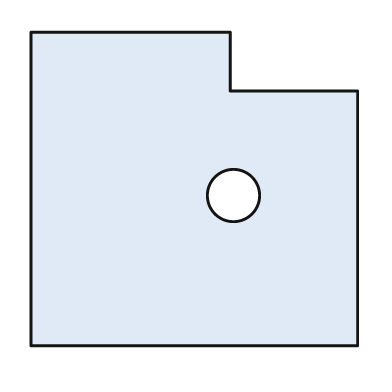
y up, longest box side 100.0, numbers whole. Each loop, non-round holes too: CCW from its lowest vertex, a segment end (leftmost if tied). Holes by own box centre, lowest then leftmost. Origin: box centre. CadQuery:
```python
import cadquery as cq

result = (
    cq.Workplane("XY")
    .moveTo(-50.0, -48.0)
    .lineTo(50.0, -48.0)
    .lineTo(50.0, 30.0)
    .lineTo(11.0, 30.0)
    .lineTo(11.0, 48.0)
    .lineTo(-50.0, 48.0)
    .close()
    .moveTo(12.0, -2.0)
    .circle(8.0)
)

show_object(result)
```